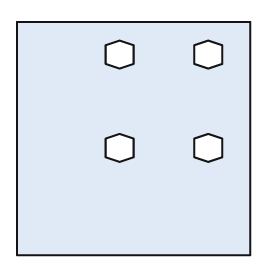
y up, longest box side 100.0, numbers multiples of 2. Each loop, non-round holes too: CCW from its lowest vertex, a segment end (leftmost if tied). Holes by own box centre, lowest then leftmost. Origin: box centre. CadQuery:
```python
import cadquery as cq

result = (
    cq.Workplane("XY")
    .moveTo(-50.0, -50.0)
    .lineTo(50.0, -50.0)
    .lineTo(50.0, 50.0)
    .lineTo(-50.0, 50.0)
    .close()
    .moveTo(-6.0, -10.0)
    .lineTo(0.0, -8.0)
    .lineTo(0.0, 0.0)
    .lineTo(-6.0, 2.0)
    .lineTo(-12.0, 0.0)
    .lineTo(-12.0, -8.0)
    .close()
    .moveTo(32.0, -10.0)
    .lineTo(38.0, -8.0)
    .lineTo(38.0, 0.0)
    .lineTo(32.0, 2.0)
    .lineTo(26.0, 0.0)
    .lineTo(26.0, -8.0)
    .close()
    .moveTo(-6.0, 30.0)
    .lineTo(0.0, 32.0)
    .lineTo(0.0, 40.0)
    .lineTo(-6.0, 42.0)
    .lineTo(-12.0, 40.0)
    .lineTo(-12.0, 32.0)
    .close()
    .moveTo(32.0, 30.0)
    .lineTo(38.0, 32.0)
    .lineTo(38.0, 40.0)
    .lineTo(32.0, 42.0)
    .lineTo(26.0, 40.0)
    .lineTo(26.0, 32.0)
    .close()
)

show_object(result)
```